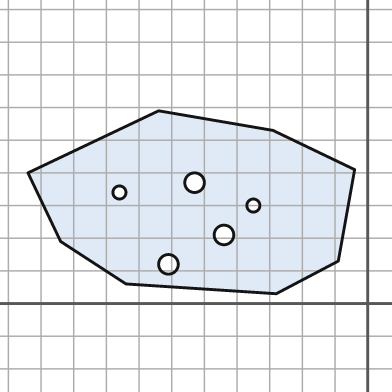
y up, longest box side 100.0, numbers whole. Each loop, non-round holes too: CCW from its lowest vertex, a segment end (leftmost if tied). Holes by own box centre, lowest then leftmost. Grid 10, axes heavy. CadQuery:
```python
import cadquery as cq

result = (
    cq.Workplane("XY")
    .moveTo(-28.0, 3.0)
    .lineTo(-9.0, 13.0)
    .lineTo(-4.0, 41.0)
    .lineTo(-29.0, 53.0)
    .lineTo(-64.0, 59.0)
    .lineTo(-104.0, 40.0)
    .lineTo(-94.0, 19.0)
    .lineTo(-74.0, 6.0)
    .close()
    .moveTo(-61.0, 12.0)
    .circle(3.0)
    .moveTo(-44.0, 21.0)
    .circle(3.0)
    .moveTo(-35.0, 30.0)
    .circle(2.0)
    .moveTo(-76.0, 34.0)
    .circle(2.0)
    .moveTo(-53.0, 37.0)
    .circle(3.0)
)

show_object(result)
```